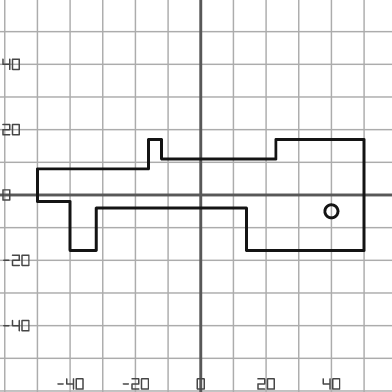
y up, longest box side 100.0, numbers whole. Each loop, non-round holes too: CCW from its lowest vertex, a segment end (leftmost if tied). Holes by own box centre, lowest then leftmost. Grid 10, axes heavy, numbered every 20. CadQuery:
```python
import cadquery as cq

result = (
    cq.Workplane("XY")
    .moveTo(-40.0, -17.0)
    .lineTo(-32.0, -17.0)
    .lineTo(-32.0, -4.0)
    .lineTo(14.0, -4.0)
    .lineTo(14.0, -17.0)
    .lineTo(50.0, -17.0)
    .lineTo(50.0, 17.0)
    .lineTo(23.0, 17.0)
    .lineTo(23.0, 11.0)
    .lineTo(-12.0, 11.0)
    .lineTo(-12.0, 17.0)
    .lineTo(-16.0, 17.0)
    .lineTo(-16.0, 8.0)
    .lineTo(-50.0, 8.0)
    .lineTo(-50.0, -2.0)
    .lineTo(-40.0, -2.0)
    .close()
    .moveTo(40.0, -5.0)
    .circle(2.0)
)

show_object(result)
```